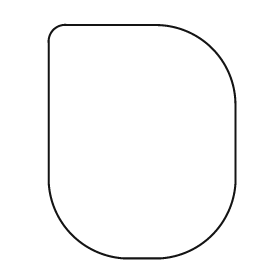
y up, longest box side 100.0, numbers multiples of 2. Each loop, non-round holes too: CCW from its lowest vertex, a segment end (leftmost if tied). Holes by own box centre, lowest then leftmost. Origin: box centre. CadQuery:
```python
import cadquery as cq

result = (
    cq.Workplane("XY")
    .moveTo(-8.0, -50.0)
    .lineTo(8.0, -50.0)
    .threePointArc((30.0, -40.0), (40.0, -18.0))
    .lineTo(40.0, 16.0)
    .threePointArc((30.0, 40.0), (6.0, 50.0))
    .lineTo(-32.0, 50.0)
    .threePointArc((-38.0, 48.0), (-40.0, 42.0))
    .lineTo(-40.0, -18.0)
    .threePointArc((-30.0, -40.0), (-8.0, -50.0))
    .close()
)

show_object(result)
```